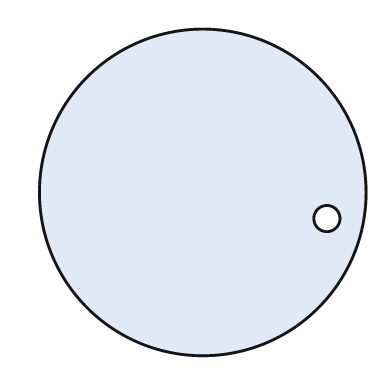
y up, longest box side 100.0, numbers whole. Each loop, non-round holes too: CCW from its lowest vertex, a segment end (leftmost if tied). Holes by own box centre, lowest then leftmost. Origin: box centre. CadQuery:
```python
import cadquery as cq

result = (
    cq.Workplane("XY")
    .moveTo(0.0, 0.0)
    .circle(50.0)
    .moveTo(38.0, -8.0)
    .circle(4.0)
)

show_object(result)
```